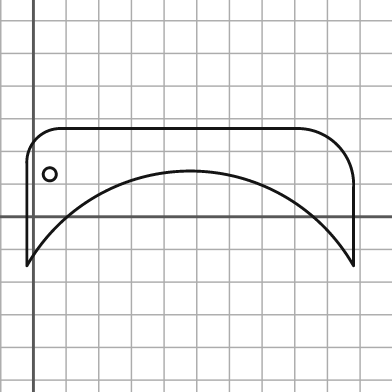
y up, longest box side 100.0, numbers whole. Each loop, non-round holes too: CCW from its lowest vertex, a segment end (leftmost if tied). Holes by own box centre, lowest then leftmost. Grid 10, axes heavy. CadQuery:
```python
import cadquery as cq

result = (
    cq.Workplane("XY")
    .moveTo(-2.0, -15.0)
    .threePointArc((48.0, 14.0), (98.0, -15.0))
    .lineTo(98.0, 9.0)
    .threePointArc((93.0, 22.0), (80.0, 27.0))
    .lineTo(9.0, 27.0)
    .threePointArc((1.0, 24.0), (-2.0, 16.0))
    .close()
    .moveTo(5.0, 13.0)
    .circle(2.0)
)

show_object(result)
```